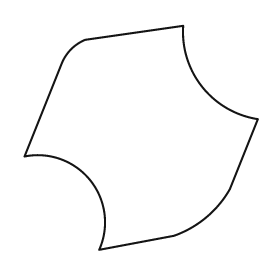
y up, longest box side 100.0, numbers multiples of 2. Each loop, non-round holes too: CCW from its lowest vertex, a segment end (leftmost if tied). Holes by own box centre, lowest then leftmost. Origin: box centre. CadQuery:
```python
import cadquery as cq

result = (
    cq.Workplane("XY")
    .moveTo(-18.0, -48.0)
    .lineTo(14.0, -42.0)
    .threePointArc((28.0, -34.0), (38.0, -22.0))
    .lineTo(50.0, 8.0)
    .threePointArc((26.0, 22.0), (18.0, 48.0))
    .lineTo(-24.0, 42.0)
    .threePointArc((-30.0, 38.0), (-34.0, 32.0))
    .lineTo(-50.0, -8.0)
    .threePointArc((-22.0, -18.0), (-18.0, -48.0))
    .close()
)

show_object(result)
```